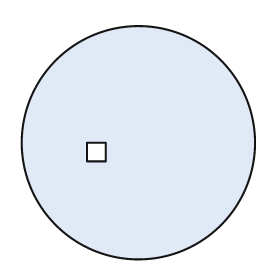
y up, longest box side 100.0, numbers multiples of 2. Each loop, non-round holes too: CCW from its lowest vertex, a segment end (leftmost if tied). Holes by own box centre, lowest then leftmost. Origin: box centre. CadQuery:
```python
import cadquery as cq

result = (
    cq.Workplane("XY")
    .moveTo(0.0, 0.0)
    .circle(50.0)
    .moveTo(-22.0, -8.0)
    .lineTo(-14.0, -8.0)
    .lineTo(-14.0, 0.0)
    .lineTo(-22.0, 0.0)
    .close()
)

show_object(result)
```